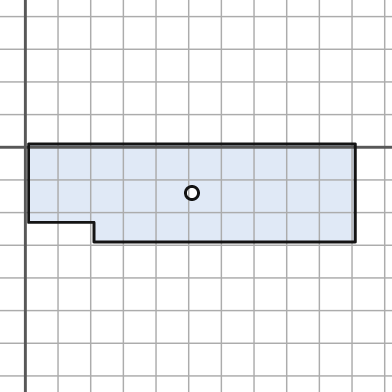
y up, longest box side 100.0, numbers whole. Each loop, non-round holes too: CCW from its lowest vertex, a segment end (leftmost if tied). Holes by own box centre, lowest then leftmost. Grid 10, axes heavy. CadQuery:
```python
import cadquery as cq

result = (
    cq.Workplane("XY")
    .moveTo(21.0, -29.0)
    .lineTo(101.0, -29.0)
    .lineTo(101.0, 1.0)
    .lineTo(1.0, 1.0)
    .lineTo(1.0, -23.0)
    .lineTo(21.0, -23.0)
    .close()
    .moveTo(51.0, -14.0)
    .circle(2.0)
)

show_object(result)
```